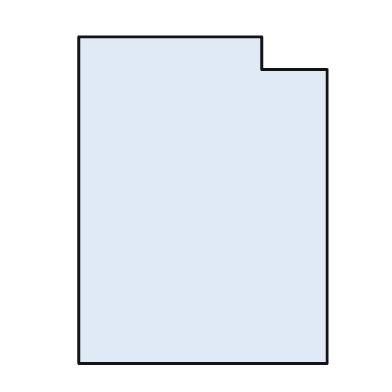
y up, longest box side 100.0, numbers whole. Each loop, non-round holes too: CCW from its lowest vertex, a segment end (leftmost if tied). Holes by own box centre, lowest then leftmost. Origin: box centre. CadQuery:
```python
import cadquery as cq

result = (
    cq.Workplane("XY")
    .moveTo(-38.0, -50.0)
    .lineTo(38.0, -50.0)
    .lineTo(38.0, 40.0)
    .lineTo(18.0, 40.0)
    .lineTo(18.0, 50.0)
    .lineTo(-38.0, 50.0)
    .close()
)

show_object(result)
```